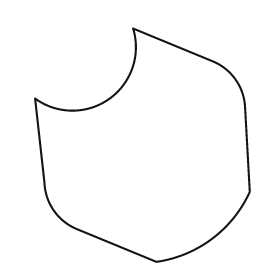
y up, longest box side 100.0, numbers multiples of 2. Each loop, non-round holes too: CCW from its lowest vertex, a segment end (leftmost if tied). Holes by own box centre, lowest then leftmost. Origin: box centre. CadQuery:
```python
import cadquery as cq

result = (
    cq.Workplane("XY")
    .moveTo(6.0, -50.0)
    .threePointArc((30.0, -40.0), (46.0, -20.0))
    .lineTo(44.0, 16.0)
    .threePointArc((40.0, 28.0), (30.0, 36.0))
    .lineTo(-4.0, 50.0)
    .threePointArc((-14.0, 20.0), (-46.0, 20.0))
    .lineTo(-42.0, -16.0)
    .threePointArc((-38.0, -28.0), (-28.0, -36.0))
    .close()
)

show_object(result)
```